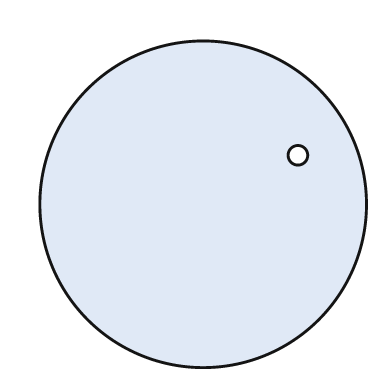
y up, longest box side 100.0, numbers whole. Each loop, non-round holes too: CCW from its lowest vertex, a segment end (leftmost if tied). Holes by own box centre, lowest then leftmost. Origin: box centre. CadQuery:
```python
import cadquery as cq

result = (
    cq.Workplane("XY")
    .moveTo(0.0, 0.0)
    .circle(50.0)
    .moveTo(29.0, 15.0)
    .circle(3.0)
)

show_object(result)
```